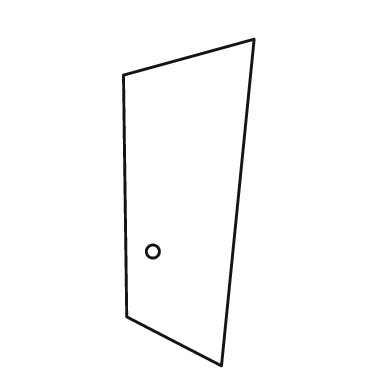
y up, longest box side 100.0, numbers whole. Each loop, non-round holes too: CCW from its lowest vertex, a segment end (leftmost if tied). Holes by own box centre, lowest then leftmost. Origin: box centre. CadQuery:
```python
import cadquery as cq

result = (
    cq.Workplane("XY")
    .moveTo(10.0, -50.0)
    .lineTo(20.0, 50.0)
    .lineTo(-20.0, 39.0)
    .lineTo(-19.0, -35.0)
    .close()
    .moveTo(-11.0, -15.0)
    .circle(2.0)
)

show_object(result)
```